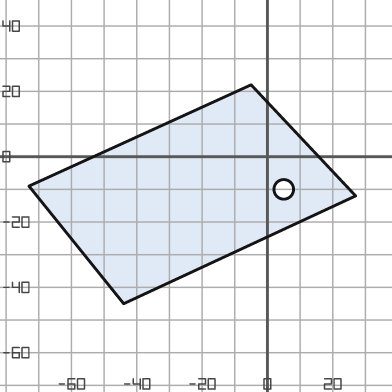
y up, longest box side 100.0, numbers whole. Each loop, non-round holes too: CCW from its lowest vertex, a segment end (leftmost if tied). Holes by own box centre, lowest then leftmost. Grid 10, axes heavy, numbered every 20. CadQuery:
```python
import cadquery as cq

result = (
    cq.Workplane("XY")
    .moveTo(-44.0, -45.0)
    .lineTo(27.0, -12.0)
    .lineTo(-5.0, 22.0)
    .lineTo(-73.0, -9.0)
    .close()
    .moveTo(5.0, -10.0)
    .circle(3.0)
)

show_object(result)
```